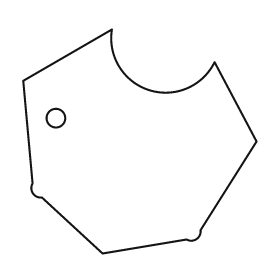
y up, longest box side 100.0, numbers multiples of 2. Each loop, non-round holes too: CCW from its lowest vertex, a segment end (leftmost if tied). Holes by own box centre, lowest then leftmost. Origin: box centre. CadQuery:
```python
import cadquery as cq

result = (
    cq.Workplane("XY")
    .moveTo(-16.0, -48.0)
    .lineTo(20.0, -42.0)
    .threePointArc((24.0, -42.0), (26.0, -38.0))
    .lineTo(50.0, 0.0)
    .lineTo(32.0, 34.0)
    .threePointArc((4.0, 22.0), (-12.0, 48.0))
    .lineTo(-50.0, 26.0)
    .lineTo(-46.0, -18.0)
    .threePointArc((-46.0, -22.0), (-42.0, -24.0))
    .close()
    .moveTo(-36.0, 10.0)
    .circle(4.0)
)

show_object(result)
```